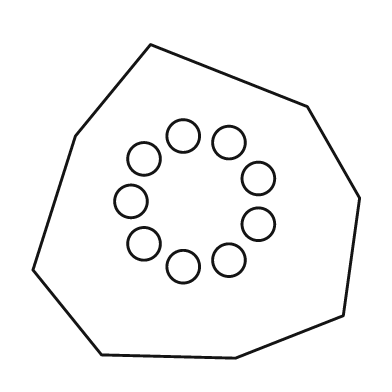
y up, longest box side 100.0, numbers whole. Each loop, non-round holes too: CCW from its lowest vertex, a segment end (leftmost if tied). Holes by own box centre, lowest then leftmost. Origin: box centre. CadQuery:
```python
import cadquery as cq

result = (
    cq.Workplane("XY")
    .moveTo(12.0, -48.0)
    .lineTo(45.0, -35.0)
    .lineTo(50.0, 1.0)
    .lineTo(34.0, 29.0)
    .lineTo(-14.0, 48.0)
    .lineTo(-37.0, 20.0)
    .lineTo(-50.0, -21.0)
    .lineTo(-29.0, -47.0)
    .close()
    .moveTo(-4.0, -20.0)
    .circle(5.0)
    .moveTo(10.0, -18.0)
    .circle(5.0)
    .moveTo(-16.0, -13.0)
    .circle(5.0)
    .moveTo(19.0, -7.0)
    .circle(5.0)
    .moveTo(-20.0, 0.0)
    .circle(5.0)
    .moveTo(19.0, 7.0)
    .circle(5.0)
    .moveTo(-16.0, 13.0)
    .circle(5.0)
    .moveTo(10.0, 18.0)
    .circle(5.0)
    .moveTo(-4.0, 20.0)
    .circle(5.0)
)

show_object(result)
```